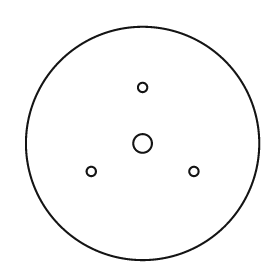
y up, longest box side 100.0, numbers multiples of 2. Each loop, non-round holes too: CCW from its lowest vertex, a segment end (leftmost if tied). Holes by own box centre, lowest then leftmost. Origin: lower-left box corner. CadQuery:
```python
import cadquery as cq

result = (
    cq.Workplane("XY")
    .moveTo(50.0, 50.0)
    .circle(50.0)
    .moveTo(28.0, 38.0)
    .circle(2.0)
    .moveTo(72.0, 38.0)
    .circle(2.0)
    .moveTo(50.0, 50.0)
    .circle(4.0)
    .moveTo(50.0, 74.0)
    .circle(2.0)
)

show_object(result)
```